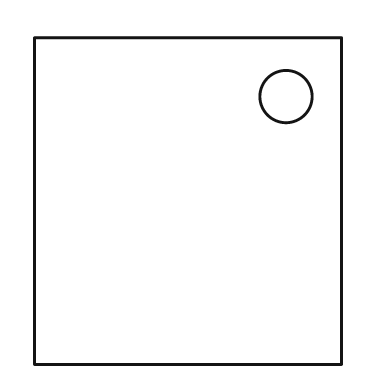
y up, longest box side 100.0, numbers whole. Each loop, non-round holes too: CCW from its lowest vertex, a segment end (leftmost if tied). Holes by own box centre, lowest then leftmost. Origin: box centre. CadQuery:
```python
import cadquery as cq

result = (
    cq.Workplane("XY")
    .moveTo(-47.0, -50.0)
    .lineTo(47.0, -50.0)
    .lineTo(47.0, 50.0)
    .lineTo(-47.0, 50.0)
    .close()
    .moveTo(30.0, 32.0)
    .circle(8.0)
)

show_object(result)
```